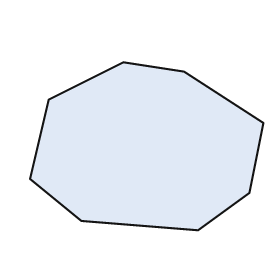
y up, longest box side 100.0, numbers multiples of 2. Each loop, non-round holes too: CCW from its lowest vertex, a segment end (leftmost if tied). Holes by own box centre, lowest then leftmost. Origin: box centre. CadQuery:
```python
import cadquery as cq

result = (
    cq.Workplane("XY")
    .moveTo(22.0, -36.0)
    .lineTo(44.0, -20.0)
    .lineTo(50.0, 10.0)
    .lineTo(16.0, 32.0)
    .lineTo(-10.0, 36.0)
    .lineTo(-42.0, 20.0)
    .lineTo(-50.0, -14.0)
    .lineTo(-28.0, -32.0)
    .close()
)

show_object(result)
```